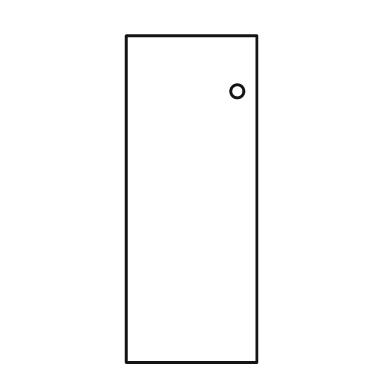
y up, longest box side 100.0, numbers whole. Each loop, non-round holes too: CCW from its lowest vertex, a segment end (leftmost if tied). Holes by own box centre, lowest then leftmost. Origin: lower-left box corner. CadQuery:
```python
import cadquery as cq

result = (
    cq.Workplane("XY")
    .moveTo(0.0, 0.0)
    .lineTo(40.0, 0.0)
    .lineTo(40.0, 100.0)
    .lineTo(0.0, 100.0)
    .close()
    .moveTo(34.0, 83.0)
    .circle(2.0)
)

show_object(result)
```